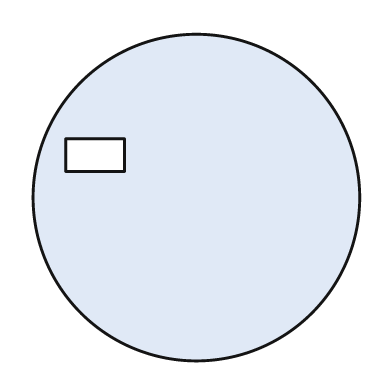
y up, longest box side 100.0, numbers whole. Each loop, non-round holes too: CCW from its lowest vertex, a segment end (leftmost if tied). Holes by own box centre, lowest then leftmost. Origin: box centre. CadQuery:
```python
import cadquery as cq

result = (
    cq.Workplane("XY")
    .moveTo(0.0, 0.0)
    .circle(50.0)
    .moveTo(-40.0, 8.0)
    .lineTo(-22.0, 8.0)
    .lineTo(-22.0, 18.0)
    .lineTo(-40.0, 18.0)
    .close()
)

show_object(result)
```